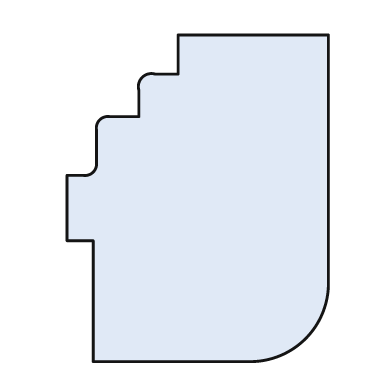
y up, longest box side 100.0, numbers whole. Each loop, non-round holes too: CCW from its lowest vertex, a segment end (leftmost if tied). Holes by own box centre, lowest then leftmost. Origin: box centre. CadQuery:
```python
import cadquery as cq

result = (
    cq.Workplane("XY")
    .moveTo(-32.0, -50.0)
    .lineTo(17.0, -50.0)
    .threePointArc((33.0, -43.0), (40.0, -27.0))
    .lineTo(40.0, 50.0)
    .lineTo(-6.0, 50.0)
    .lineTo(-6.0, 38.0)
    .lineTo(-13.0, 38.0)
    .threePointArc((-17.0, 37.0), (-18.0, 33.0))
    .lineTo(-18.0, 25.0)
    .lineTo(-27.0, 25.0)
    .threePointArc((-30.0, 24.0), (-31.0, 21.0))
    .lineTo(-31.0, 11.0)
    .threePointArc((-32.0, 8.0), (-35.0, 7.0))
    .lineTo(-40.0, 7.0)
    .lineTo(-40.0, -13.0)
    .lineTo(-32.0, -13.0)
    .close()
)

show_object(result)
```